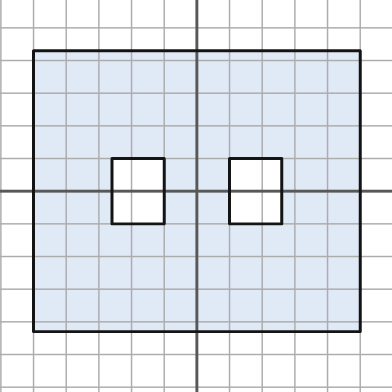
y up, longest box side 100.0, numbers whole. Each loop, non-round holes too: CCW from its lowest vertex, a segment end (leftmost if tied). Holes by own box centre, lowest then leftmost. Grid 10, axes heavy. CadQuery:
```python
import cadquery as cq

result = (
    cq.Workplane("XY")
    .moveTo(-50.0, -43.0)
    .lineTo(50.0, -43.0)
    .lineTo(50.0, 43.0)
    .lineTo(-50.0, 43.0)
    .close()
    .moveTo(-26.0, -10.0)
    .lineTo(-10.0, -10.0)
    .lineTo(-10.0, 10.0)
    .lineTo(-26.0, 10.0)
    .close()
    .moveTo(10.0, -10.0)
    .lineTo(26.0, -10.0)
    .lineTo(26.0, 10.0)
    .lineTo(10.0, 10.0)
    .close()
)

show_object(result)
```